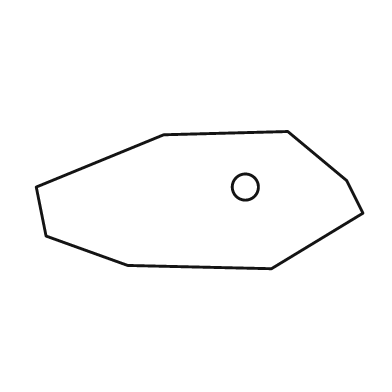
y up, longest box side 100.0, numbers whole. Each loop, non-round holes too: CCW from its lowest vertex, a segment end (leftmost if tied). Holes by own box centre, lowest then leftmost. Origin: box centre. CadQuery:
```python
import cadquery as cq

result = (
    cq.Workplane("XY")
    .moveTo(22.0, -21.0)
    .lineTo(50.0, -4.0)
    .lineTo(45.0, 6.0)
    .lineTo(27.0, 21.0)
    .lineTo(-11.0, 20.0)
    .lineTo(-50.0, 4.0)
    .lineTo(-47.0, -11.0)
    .lineTo(-22.0, -20.0)
    .close()
    .moveTo(14.0, 4.0)
    .circle(4.0)
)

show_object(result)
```